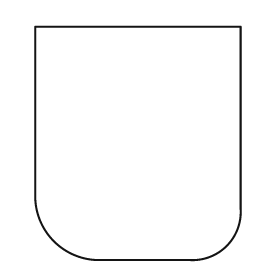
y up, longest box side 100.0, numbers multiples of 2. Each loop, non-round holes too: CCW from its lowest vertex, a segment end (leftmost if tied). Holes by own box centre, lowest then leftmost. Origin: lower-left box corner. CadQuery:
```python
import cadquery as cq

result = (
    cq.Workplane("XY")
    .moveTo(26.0, 0.0)
    .lineTo(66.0, 0.0)
    .threePointArc((82.0, 6.0), (88.0, 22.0))
    .lineTo(88.0, 100.0)
    .lineTo(0.0, 100.0)
    .lineTo(0.0, 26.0)
    .threePointArc((8.0, 8.0), (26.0, 0.0))
    .close()
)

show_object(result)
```